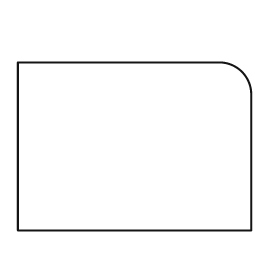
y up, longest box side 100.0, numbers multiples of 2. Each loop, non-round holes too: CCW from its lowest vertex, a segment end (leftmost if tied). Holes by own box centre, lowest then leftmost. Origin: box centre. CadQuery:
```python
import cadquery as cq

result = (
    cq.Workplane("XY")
    .moveTo(-50.0, -36.0)
    .lineTo(50.0, -36.0)
    .lineTo(50.0, 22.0)
    .threePointArc((46.0, 32.0), (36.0, 36.0))
    .lineTo(-50.0, 36.0)
    .close()
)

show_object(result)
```